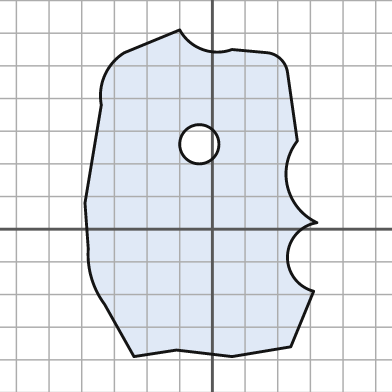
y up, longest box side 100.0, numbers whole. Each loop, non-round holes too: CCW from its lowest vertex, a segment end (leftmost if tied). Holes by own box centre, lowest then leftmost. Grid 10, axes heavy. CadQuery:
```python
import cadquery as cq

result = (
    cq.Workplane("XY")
    .moveTo(-24.0, -39.0)
    .lineTo(-11.0, -37.0)
    .lineTo(6.0, -39.0)
    .lineTo(24.0, -36.0)
    .lineTo(31.0, -19.0)
    .threePointArc((23.0, -8.0), (32.0, 2.0))
    .threePointArc((23.0, 13.0), (26.0, 27.0))
    .lineTo(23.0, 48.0)
    .threePointArc((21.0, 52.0), (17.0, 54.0))
    .lineTo(6.0, 55.0)
    .threePointArc((-3.0, 55.0), (-10.0, 61.0))
    .lineTo(-27.0, 54.0)
    .threePointArc((-33.0, 47.0), (-34.0, 38.0))
    .lineTo(-39.0, 8.0)
    .lineTo(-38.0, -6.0)
    .threePointArc((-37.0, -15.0), (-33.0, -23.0))
    .close()
    .moveTo(-4.0, 26.0)
    .circle(6.0)
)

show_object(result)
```